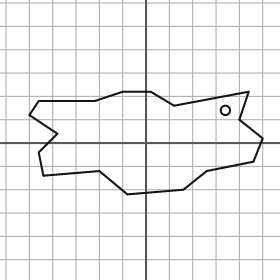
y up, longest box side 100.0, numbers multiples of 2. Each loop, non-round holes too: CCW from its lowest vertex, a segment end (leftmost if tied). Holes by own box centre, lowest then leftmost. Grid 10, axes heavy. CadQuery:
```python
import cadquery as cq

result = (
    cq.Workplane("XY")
    .moveTo(-8.0, -22.0)
    .lineTo(16.0, -20.0)
    .lineTo(26.0, -12.0)
    .lineTo(46.0, -8.0)
    .lineTo(50.0, 2.0)
    .lineTo(40.0, 10.0)
    .lineTo(44.0, 22.0)
    .lineTo(12.0, 16.0)
    .lineTo(2.0, 22.0)
    .lineTo(-10.0, 22.0)
    .lineTo(-22.0, 18.0)
    .lineTo(-46.0, 18.0)
    .lineTo(-50.0, 12.0)
    .lineTo(-38.0, 4.0)
    .lineTo(-46.0, -4.0)
    .lineTo(-44.0, -14.0)
    .lineTo(-20.0, -12.0)
    .close()
    .moveTo(34.0, 14.0)
    .circle(2.0)
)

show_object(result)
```